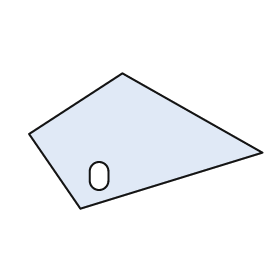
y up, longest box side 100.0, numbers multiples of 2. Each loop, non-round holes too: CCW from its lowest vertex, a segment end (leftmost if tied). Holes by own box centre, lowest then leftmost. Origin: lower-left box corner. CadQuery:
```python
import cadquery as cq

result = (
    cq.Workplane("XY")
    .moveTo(22.0, 0.0)
    .lineTo(100.0, 24.0)
    .lineTo(40.0, 58.0)
    .lineTo(0.0, 32.0)
    .close()
    .moveTo(26.0, 12.0)
    .threePointArc((30.0, 8.0), (34.0, 12.0))
    .lineTo(34.0, 16.0)
    .threePointArc((30.0, 20.0), (26.0, 16.0))
    .close()
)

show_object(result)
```